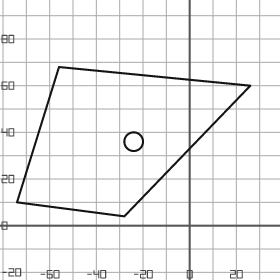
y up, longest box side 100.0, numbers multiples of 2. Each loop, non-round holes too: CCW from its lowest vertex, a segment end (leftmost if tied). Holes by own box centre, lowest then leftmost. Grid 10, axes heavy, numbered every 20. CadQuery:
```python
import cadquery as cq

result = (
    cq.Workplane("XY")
    .moveTo(-28.0, 4.0)
    .lineTo(26.0, 60.0)
    .lineTo(-56.0, 68.0)
    .lineTo(-74.0, 10.0)
    .close()
    .moveTo(-24.0, 36.0)
    .circle(4.0)
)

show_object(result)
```